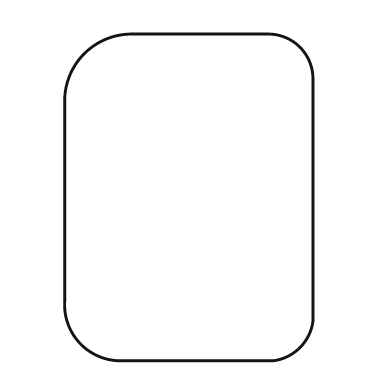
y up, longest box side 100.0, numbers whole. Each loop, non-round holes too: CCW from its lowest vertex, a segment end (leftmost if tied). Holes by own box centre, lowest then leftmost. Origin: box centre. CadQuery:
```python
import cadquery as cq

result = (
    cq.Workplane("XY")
    .moveTo(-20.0, -50.0)
    .lineTo(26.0, -50.0)
    .threePointArc((34.0, -46.0), (38.0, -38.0))
    .lineTo(38.0, 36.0)
    .threePointArc((34.0, 46.0), (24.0, 50.0))
    .lineTo(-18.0, 50.0)
    .threePointArc((-32.0, 44.0), (-38.0, 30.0))
    .lineTo(-38.0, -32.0)
    .threePointArc((-33.0, -45.0), (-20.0, -50.0))
    .close()
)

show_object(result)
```